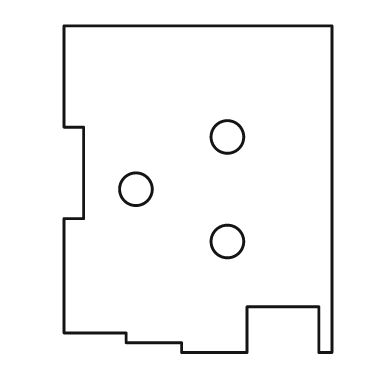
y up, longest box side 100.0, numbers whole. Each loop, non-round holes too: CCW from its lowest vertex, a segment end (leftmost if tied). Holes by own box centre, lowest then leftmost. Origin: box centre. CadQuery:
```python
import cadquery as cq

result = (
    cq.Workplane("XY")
    .moveTo(-5.0, -50.0)
    .lineTo(15.0, -50.0)
    .lineTo(15.0, -36.0)
    .lineTo(37.0, -36.0)
    .lineTo(37.0, -50.0)
    .lineTo(41.0, -50.0)
    .lineTo(41.0, 50.0)
    .lineTo(-41.0, 50.0)
    .lineTo(-41.0, 19.0)
    .lineTo(-35.0, 19.0)
    .lineTo(-35.0, -9.0)
    .lineTo(-41.0, -9.0)
    .lineTo(-41.0, -44.0)
    .lineTo(-22.0, -44.0)
    .lineTo(-22.0, -47.0)
    .lineTo(-5.0, -47.0)
    .close()
    .moveTo(9.0, -16.0)
    .circle(5.0)
    .moveTo(-19.0, 0.0)
    .circle(5.0)
    .moveTo(9.0, 16.0)
    .circle(5.0)
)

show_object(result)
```